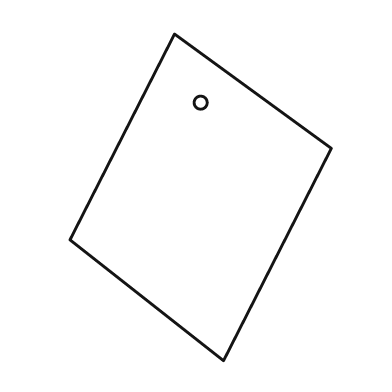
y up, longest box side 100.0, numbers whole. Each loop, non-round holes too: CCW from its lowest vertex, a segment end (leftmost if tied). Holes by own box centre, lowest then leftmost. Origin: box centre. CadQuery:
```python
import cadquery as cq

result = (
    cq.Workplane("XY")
    .moveTo(7.0, -50.0)
    .lineTo(40.0, 15.0)
    .lineTo(-8.0, 50.0)
    .lineTo(-40.0, -13.0)
    .close()
    .moveTo(0.0, 29.0)
    .circle(2.0)
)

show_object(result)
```